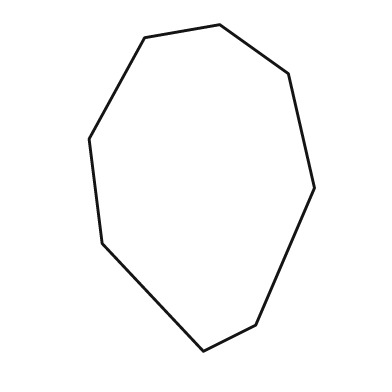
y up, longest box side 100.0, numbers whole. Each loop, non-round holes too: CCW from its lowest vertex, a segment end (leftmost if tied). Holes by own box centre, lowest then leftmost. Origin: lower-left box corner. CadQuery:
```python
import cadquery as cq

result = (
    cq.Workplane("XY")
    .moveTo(35.0, 0.0)
    .lineTo(51.0, 8.0)
    .lineTo(69.0, 50.0)
    .lineTo(61.0, 85.0)
    .lineTo(40.0, 100.0)
    .lineTo(17.0, 96.0)
    .lineTo(0.0, 65.0)
    .lineTo(4.0, 33.0)
    .close()
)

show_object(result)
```